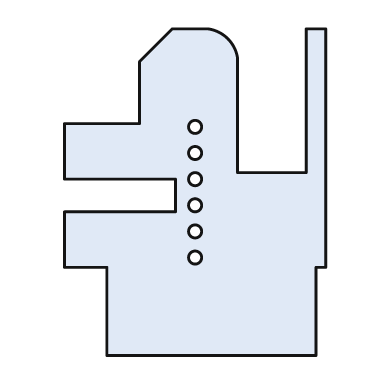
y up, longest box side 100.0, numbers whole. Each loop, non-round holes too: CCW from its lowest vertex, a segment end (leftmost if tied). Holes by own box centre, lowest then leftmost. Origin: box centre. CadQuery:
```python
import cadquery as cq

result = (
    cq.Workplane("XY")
    .moveTo(-27.0, -50.0)
    .lineTo(37.0, -50.0)
    .lineTo(37.0, -23.0)
    .lineTo(40.0, -23.0)
    .lineTo(40.0, 50.0)
    .lineTo(34.0, 50.0)
    .lineTo(34.0, 6.0)
    .lineTo(13.0, 6.0)
    .lineTo(13.0, 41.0)
    .threePointArc((10.0, 47.0), (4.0, 50.0))
    .lineTo(-7.0, 50.0)
    .lineTo(-17.0, 40.0)
    .lineTo(-17.0, 21.0)
    .lineTo(-40.0, 21.0)
    .lineTo(-40.0, 4.0)
    .lineTo(-6.0, 4.0)
    .lineTo(-6.0, -6.0)
    .lineTo(-40.0, -6.0)
    .lineTo(-40.0, -23.0)
    .lineTo(-27.0, -23.0)
    .close()
    .moveTo(0.0, -20.0)
    .circle(2.0)
    .moveTo(0.0, -12.0)
    .circle(2.0)
    .moveTo(0.0, -4.0)
    .circle(2.0)
    .moveTo(0.0, 4.0)
    .circle(2.0)
    .moveTo(0.0, 12.0)
    .circle(2.0)
    .moveTo(0.0, 20.0)
    .circle(2.0)
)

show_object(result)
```